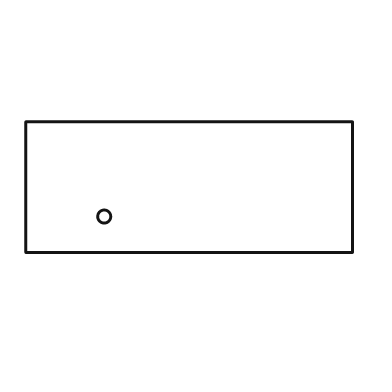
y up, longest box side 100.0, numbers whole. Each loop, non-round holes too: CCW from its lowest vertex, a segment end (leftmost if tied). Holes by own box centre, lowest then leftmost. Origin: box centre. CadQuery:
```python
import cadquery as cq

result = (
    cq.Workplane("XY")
    .moveTo(-50.0, -20.0)
    .lineTo(50.0, -20.0)
    .lineTo(50.0, 20.0)
    .lineTo(-50.0, 20.0)
    .close()
    .moveTo(-26.0, -9.0)
    .circle(2.0)
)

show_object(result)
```